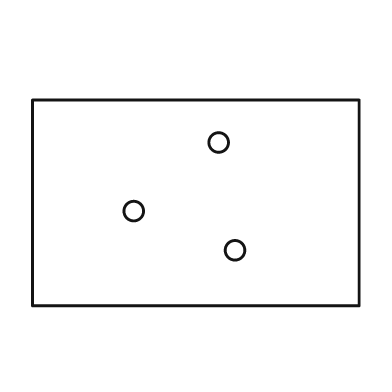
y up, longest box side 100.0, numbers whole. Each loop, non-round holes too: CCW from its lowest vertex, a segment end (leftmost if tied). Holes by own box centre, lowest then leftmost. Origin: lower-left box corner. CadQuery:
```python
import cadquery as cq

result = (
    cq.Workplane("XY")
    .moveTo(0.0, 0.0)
    .lineTo(100.0, 0.0)
    .lineTo(100.0, 63.0)
    .lineTo(0.0, 63.0)
    .close()
    .moveTo(62.0, 17.0)
    .circle(3.0)
    .moveTo(31.0, 29.0)
    .circle(3.0)
    .moveTo(57.0, 50.0)
    .circle(3.0)
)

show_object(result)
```